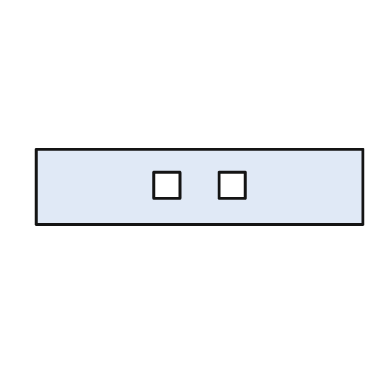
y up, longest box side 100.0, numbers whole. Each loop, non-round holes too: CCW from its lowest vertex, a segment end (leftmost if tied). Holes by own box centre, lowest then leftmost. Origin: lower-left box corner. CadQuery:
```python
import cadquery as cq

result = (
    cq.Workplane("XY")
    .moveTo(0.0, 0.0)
    .lineTo(100.0, 0.0)
    .lineTo(100.0, 23.0)
    .lineTo(0.0, 23.0)
    .close()
    .moveTo(36.0, 8.0)
    .lineTo(44.0, 8.0)
    .lineTo(44.0, 16.0)
    .lineTo(36.0, 16.0)
    .close()
    .moveTo(56.0, 8.0)
    .lineTo(64.0, 8.0)
    .lineTo(64.0, 16.0)
    .lineTo(56.0, 16.0)
    .close()
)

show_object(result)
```